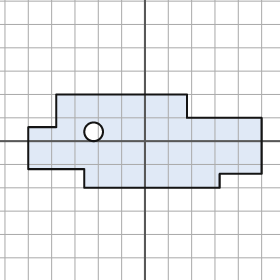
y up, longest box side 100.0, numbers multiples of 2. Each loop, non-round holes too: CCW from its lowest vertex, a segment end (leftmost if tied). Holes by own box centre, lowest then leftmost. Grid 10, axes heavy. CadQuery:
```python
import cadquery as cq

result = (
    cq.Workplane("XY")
    .moveTo(-26.0, -20.0)
    .lineTo(32.0, -20.0)
    .lineTo(32.0, -14.0)
    .lineTo(50.0, -14.0)
    .lineTo(50.0, 10.0)
    .lineTo(18.0, 10.0)
    .lineTo(18.0, 20.0)
    .lineTo(-38.0, 20.0)
    .lineTo(-38.0, 6.0)
    .lineTo(-50.0, 6.0)
    .lineTo(-50.0, -12.0)
    .lineTo(-26.0, -12.0)
    .close()
    .moveTo(-22.0, 4.0)
    .circle(4.0)
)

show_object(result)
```